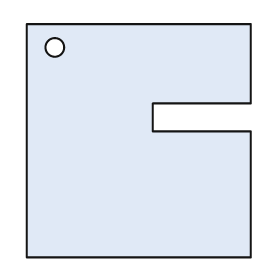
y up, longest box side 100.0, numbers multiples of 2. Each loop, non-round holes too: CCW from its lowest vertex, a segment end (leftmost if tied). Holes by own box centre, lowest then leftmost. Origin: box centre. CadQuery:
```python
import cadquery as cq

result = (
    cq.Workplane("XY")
    .moveTo(-48.0, -50.0)
    .lineTo(48.0, -50.0)
    .lineTo(48.0, 4.0)
    .lineTo(6.0, 4.0)
    .lineTo(6.0, 16.0)
    .lineTo(48.0, 16.0)
    .lineTo(48.0, 50.0)
    .lineTo(-48.0, 50.0)
    .close()
    .moveTo(-36.0, 40.0)
    .circle(4.0)
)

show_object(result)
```